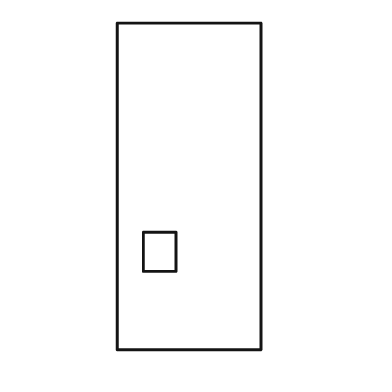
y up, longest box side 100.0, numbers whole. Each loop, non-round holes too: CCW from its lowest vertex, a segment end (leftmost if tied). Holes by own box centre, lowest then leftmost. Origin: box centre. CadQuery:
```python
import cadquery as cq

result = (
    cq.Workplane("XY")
    .moveTo(-22.0, -50.0)
    .lineTo(22.0, -50.0)
    .lineTo(22.0, 50.0)
    .lineTo(-22.0, 50.0)
    .close()
    .moveTo(-14.0, -26.0)
    .lineTo(-4.0, -26.0)
    .lineTo(-4.0, -14.0)
    .lineTo(-14.0, -14.0)
    .close()
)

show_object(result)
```